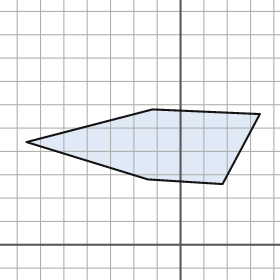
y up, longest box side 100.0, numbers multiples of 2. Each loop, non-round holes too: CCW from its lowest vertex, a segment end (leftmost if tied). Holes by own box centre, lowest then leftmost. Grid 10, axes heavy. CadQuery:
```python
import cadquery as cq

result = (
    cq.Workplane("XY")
    .moveTo(18.0, 26.0)
    .lineTo(34.0, 56.0)
    .lineTo(-12.0, 58.0)
    .lineTo(-66.0, 44.0)
    .lineTo(-14.0, 28.0)
    .close()
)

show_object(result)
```